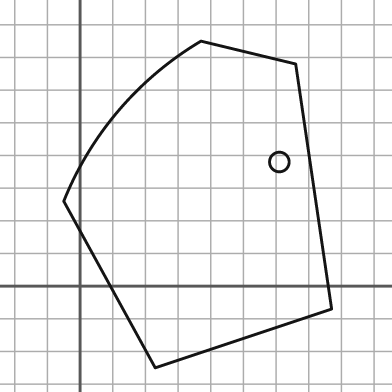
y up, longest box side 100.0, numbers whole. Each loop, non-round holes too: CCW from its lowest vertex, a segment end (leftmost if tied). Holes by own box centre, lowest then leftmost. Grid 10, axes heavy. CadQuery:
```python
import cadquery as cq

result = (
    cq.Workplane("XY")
    .moveTo(23.0, -25.0)
    .lineTo(77.0, -7.0)
    .lineTo(66.0, 68.0)
    .lineTo(37.0, 75.0)
    .threePointArc((12.0, 54.0), (-5.0, 26.0))
    .close()
    .moveTo(61.0, 38.0)
    .circle(3.0)
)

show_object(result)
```